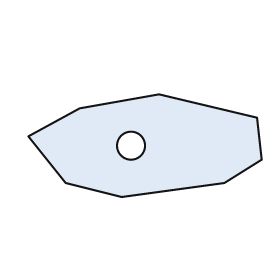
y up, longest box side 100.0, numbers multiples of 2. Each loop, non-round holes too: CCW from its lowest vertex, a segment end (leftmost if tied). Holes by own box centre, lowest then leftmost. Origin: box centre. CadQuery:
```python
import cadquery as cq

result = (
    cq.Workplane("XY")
    .moveTo(-10.0, -22.0)
    .lineTo(34.0, -16.0)
    .lineTo(50.0, -6.0)
    .lineTo(48.0, 12.0)
    .lineTo(6.0, 22.0)
    .lineTo(-28.0, 16.0)
    .lineTo(-50.0, 4.0)
    .lineTo(-34.0, -16.0)
    .close()
    .moveTo(-6.0, 0.0)
    .circle(6.0)
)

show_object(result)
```